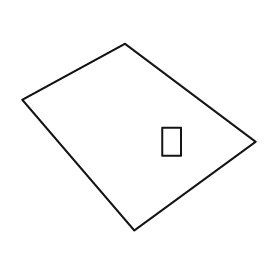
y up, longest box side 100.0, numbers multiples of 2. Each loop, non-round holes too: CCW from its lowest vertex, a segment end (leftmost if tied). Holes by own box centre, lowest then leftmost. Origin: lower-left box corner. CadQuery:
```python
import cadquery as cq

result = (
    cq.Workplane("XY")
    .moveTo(48.0, 0.0)
    .lineTo(100.0, 38.0)
    .lineTo(44.0, 80.0)
    .lineTo(0.0, 56.0)
    .close()
    .moveTo(60.0, 32.0)
    .lineTo(68.0, 32.0)
    .lineTo(68.0, 44.0)
    .lineTo(60.0, 44.0)
    .close()
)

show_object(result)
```